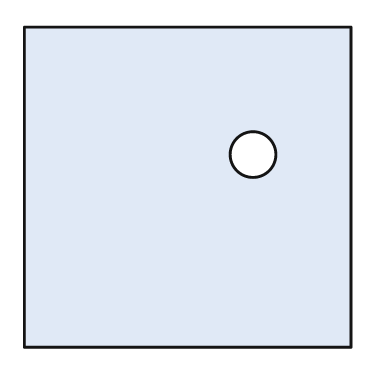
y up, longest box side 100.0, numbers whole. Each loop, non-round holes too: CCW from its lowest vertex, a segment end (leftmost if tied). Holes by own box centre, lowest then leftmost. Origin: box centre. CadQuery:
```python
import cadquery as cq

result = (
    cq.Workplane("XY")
    .moveTo(-50.0, -49.0)
    .lineTo(50.0, -49.0)
    .lineTo(50.0, 49.0)
    .lineTo(-50.0, 49.0)
    .close()
    .moveTo(20.0, 10.0)
    .circle(7.0)
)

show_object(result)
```